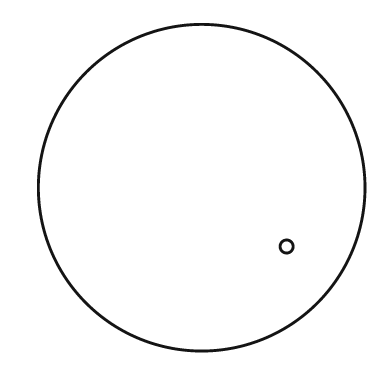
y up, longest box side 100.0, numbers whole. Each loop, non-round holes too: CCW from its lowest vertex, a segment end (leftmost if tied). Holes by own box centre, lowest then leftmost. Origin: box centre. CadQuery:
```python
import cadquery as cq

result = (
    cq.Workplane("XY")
    .moveTo(0.0, 0.0)
    .circle(50.0)
    .moveTo(26.0, -18.0)
    .circle(2.0)
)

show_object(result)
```